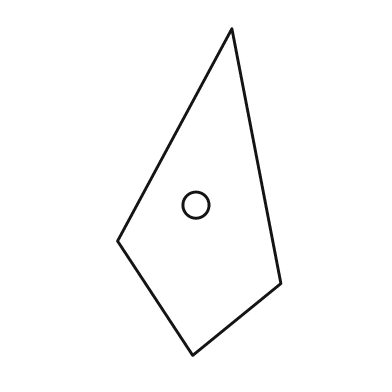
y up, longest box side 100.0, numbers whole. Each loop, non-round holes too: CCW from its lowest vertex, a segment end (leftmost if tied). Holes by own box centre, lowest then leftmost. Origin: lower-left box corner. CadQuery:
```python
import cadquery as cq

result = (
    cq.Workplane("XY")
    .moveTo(23.0, 0.0)
    .lineTo(50.0, 22.0)
    .lineTo(35.0, 100.0)
    .lineTo(0.0, 35.0)
    .close()
    .moveTo(24.0, 46.0)
    .circle(4.0)
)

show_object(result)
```